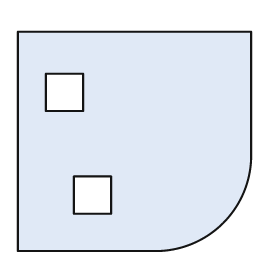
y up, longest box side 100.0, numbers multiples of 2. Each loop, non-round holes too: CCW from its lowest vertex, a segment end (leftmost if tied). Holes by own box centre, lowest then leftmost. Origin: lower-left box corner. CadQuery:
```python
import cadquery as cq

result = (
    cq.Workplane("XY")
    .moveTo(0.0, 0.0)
    .lineTo(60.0, 0.0)
    .threePointArc((88.0, 12.0), (100.0, 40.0))
    .lineTo(100.0, 94.0)
    .lineTo(0.0, 94.0)
    .close()
    .moveTo(24.0, 16.0)
    .lineTo(40.0, 16.0)
    .lineTo(40.0, 32.0)
    .lineTo(24.0, 32.0)
    .close()
    .moveTo(12.0, 60.0)
    .lineTo(28.0, 60.0)
    .lineTo(28.0, 76.0)
    .lineTo(12.0, 76.0)
    .close()
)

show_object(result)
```